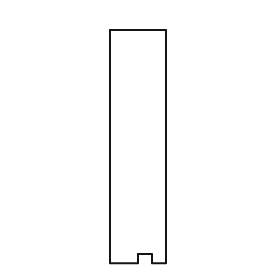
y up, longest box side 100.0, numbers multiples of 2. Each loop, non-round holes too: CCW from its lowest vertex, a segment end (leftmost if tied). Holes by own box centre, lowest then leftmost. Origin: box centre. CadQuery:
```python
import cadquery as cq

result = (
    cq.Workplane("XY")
    .moveTo(-12.0, -50.0)
    .lineTo(0.0, -50.0)
    .lineTo(0.0, -46.0)
    .lineTo(6.0, -46.0)
    .lineTo(6.0, -50.0)
    .lineTo(12.0, -50.0)
    .lineTo(12.0, 50.0)
    .lineTo(-12.0, 50.0)
    .close()
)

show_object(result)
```